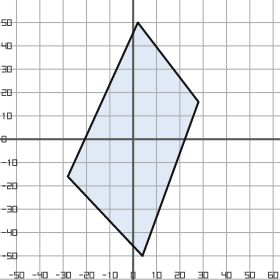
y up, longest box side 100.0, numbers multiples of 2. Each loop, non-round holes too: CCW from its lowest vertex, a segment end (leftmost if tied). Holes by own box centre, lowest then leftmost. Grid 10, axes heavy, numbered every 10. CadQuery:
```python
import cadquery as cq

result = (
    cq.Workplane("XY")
    .moveTo(4.0, -50.0)
    .lineTo(28.0, 16.0)
    .lineTo(2.0, 50.0)
    .lineTo(-28.0, -16.0)
    .close()
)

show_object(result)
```